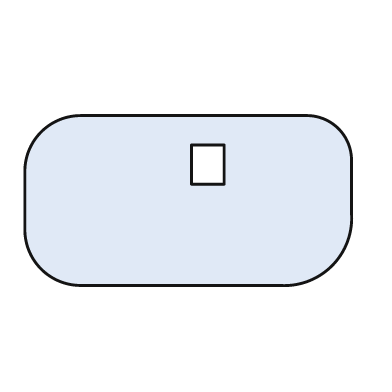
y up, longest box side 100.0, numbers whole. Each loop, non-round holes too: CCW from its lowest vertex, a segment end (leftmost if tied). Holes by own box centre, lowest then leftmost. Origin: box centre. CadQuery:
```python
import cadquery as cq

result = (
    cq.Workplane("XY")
    .moveTo(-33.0, -26.0)
    .lineTo(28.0, -26.0)
    .threePointArc((44.0, -20.0), (50.0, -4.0))
    .lineTo(50.0, 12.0)
    .threePointArc((46.0, 22.0), (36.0, 26.0))
    .lineTo(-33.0, 26.0)
    .threePointArc((-45.0, 21.0), (-50.0, 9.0))
    .lineTo(-50.0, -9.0)
    .threePointArc((-45.0, -21.0), (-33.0, -26.0))
    .close()
    .moveTo(1.0, 5.0)
    .lineTo(11.0, 5.0)
    .lineTo(11.0, 17.0)
    .lineTo(1.0, 17.0)
    .close()
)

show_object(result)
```